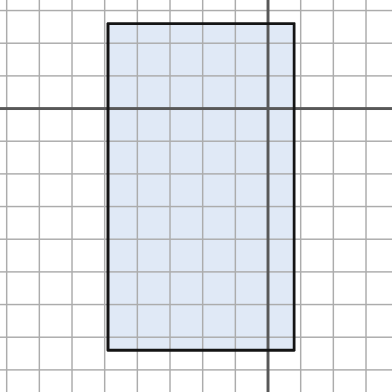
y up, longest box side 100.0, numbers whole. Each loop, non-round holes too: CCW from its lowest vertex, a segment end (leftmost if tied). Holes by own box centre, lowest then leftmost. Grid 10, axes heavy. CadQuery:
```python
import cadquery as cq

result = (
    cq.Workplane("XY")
    .moveTo(-49.0, -74.0)
    .lineTo(8.0, -74.0)
    .lineTo(8.0, 26.0)
    .lineTo(-49.0, 26.0)
    .close()
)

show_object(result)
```